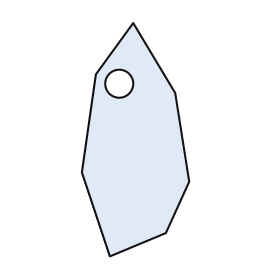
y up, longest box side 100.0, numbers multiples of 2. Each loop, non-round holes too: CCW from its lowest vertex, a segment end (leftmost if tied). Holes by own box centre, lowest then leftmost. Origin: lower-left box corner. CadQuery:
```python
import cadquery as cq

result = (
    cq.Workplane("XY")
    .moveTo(12.0, 0.0)
    .lineTo(36.0, 10.0)
    .lineTo(46.0, 32.0)
    .lineTo(40.0, 70.0)
    .lineTo(22.0, 100.0)
    .lineTo(6.0, 78.0)
    .lineTo(0.0, 36.0)
    .close()
    .moveTo(16.0, 74.0)
    .circle(6.0)
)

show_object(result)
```